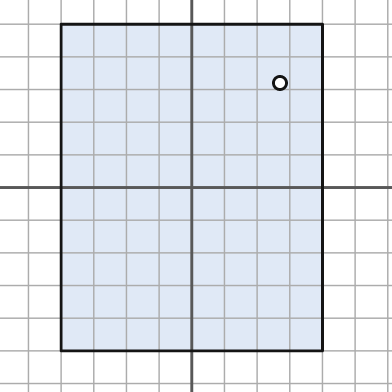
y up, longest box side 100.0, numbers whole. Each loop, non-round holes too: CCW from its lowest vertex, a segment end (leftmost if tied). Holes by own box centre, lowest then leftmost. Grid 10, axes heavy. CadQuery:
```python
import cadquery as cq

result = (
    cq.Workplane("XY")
    .moveTo(-40.0, -50.0)
    .lineTo(40.0, -50.0)
    .lineTo(40.0, 50.0)
    .lineTo(-40.0, 50.0)
    .close()
    .moveTo(27.0, 32.0)
    .circle(2.0)
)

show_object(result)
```